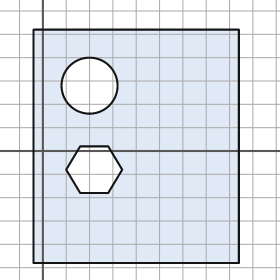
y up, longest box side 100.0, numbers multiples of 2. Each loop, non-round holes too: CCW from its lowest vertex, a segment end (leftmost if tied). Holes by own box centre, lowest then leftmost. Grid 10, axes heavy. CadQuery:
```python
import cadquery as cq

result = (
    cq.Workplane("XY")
    .moveTo(-4.0, -48.0)
    .lineTo(84.0, -48.0)
    .lineTo(84.0, 52.0)
    .lineTo(-4.0, 52.0)
    .close()
    .moveTo(16.0, -18.0)
    .lineTo(28.0, -18.0)
    .lineTo(34.0, -8.0)
    .lineTo(28.0, 2.0)
    .lineTo(16.0, 2.0)
    .lineTo(10.0, -8.0)
    .close()
    .moveTo(20.0, 28.0)
    .circle(12.0)
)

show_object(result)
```